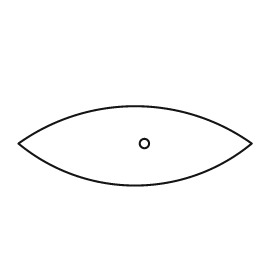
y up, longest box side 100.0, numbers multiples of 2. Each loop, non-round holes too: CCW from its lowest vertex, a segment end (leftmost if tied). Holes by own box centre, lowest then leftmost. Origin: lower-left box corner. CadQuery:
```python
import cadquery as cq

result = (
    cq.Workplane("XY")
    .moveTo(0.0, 18.0)
    .threePointArc((50.0, 0.0), (100.0, 18.0))
    .threePointArc((50.0, 34.0), (0.0, 18.0))
    .close()
    .moveTo(54.0, 18.0)
    .circle(2.0)
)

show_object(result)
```